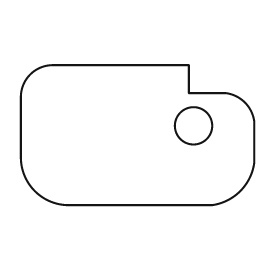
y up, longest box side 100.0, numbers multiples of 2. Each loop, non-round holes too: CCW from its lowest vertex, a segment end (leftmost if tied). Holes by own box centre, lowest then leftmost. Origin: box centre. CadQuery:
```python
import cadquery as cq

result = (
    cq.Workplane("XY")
    .moveTo(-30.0, -30.0)
    .lineTo(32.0, -30.0)
    .threePointArc((44.0, -24.0), (50.0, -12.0))
    .lineTo(50.0, 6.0)
    .threePointArc((46.0, 14.0), (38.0, 18.0))
    .lineTo(22.0, 18.0)
    .lineTo(22.0, 30.0)
    .lineTo(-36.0, 30.0)
    .threePointArc((-46.0, 26.0), (-50.0, 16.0))
    .lineTo(-50.0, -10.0)
    .threePointArc((-44.0, -24.0), (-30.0, -30.0))
    .close()
    .moveTo(24.0, 4.0)
    .circle(8.0)
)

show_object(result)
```